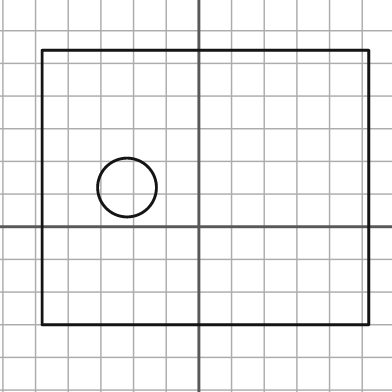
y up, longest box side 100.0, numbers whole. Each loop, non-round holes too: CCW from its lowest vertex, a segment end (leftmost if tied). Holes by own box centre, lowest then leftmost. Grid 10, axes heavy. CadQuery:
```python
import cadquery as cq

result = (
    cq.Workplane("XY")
    .moveTo(-48.0, -30.0)
    .lineTo(52.0, -30.0)
    .lineTo(52.0, 54.0)
    .lineTo(-48.0, 54.0)
    .close()
    .moveTo(-22.0, 12.0)
    .circle(9.0)
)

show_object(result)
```